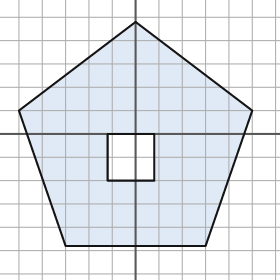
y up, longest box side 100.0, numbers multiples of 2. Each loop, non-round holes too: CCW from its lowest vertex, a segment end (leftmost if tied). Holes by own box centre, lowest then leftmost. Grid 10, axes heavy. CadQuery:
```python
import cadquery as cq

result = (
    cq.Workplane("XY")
    .moveTo(-30.0, -48.0)
    .lineTo(30.0, -48.0)
    .lineTo(50.0, 10.0)
    .lineTo(0.0, 48.0)
    .lineTo(-50.0, 10.0)
    .close()
    .moveTo(-12.0, -20.0)
    .lineTo(8.0, -20.0)
    .lineTo(8.0, 0.0)
    .lineTo(-12.0, 0.0)
    .close()
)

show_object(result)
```